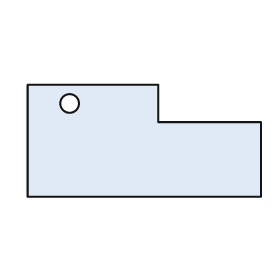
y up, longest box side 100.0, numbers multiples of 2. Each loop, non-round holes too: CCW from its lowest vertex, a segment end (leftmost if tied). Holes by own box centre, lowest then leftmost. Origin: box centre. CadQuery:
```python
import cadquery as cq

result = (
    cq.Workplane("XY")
    .moveTo(-50.0, -24.0)
    .lineTo(50.0, -24.0)
    .lineTo(50.0, 8.0)
    .lineTo(6.0, 8.0)
    .lineTo(6.0, 24.0)
    .lineTo(-50.0, 24.0)
    .close()
    .moveTo(-32.0, 16.0)
    .circle(4.0)
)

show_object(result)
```